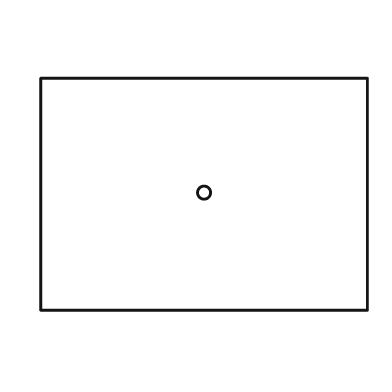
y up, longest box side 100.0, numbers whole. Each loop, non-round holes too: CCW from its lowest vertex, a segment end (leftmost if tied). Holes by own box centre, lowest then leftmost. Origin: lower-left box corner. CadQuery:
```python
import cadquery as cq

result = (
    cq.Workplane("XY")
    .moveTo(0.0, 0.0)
    .lineTo(100.0, 0.0)
    .lineTo(100.0, 71.0)
    .lineTo(0.0, 71.0)
    .close()
    .moveTo(50.0, 36.0)
    .circle(2.0)
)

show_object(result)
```